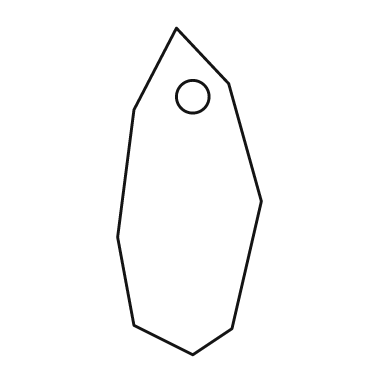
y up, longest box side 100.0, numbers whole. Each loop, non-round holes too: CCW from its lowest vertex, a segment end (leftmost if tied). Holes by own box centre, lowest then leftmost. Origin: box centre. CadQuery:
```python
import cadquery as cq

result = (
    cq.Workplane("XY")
    .moveTo(1.0, -50.0)
    .lineTo(13.0, -42.0)
    .lineTo(22.0, -3.0)
    .lineTo(12.0, 33.0)
    .lineTo(-4.0, 50.0)
    .lineTo(-17.0, 25.0)
    .lineTo(-22.0, -14.0)
    .lineTo(-17.0, -41.0)
    .close()
    .moveTo(1.0, 29.0)
    .circle(5.0)
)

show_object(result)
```